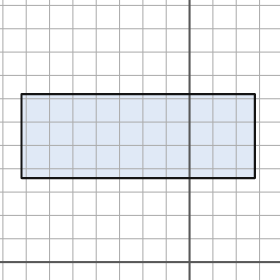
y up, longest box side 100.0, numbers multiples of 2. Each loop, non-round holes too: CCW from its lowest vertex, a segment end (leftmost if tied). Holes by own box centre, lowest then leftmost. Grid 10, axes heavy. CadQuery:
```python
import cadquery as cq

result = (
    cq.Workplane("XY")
    .moveTo(-72.0, 36.0)
    .lineTo(28.0, 36.0)
    .lineTo(28.0, 72.0)
    .lineTo(-72.0, 72.0)
    .close()
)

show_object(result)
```